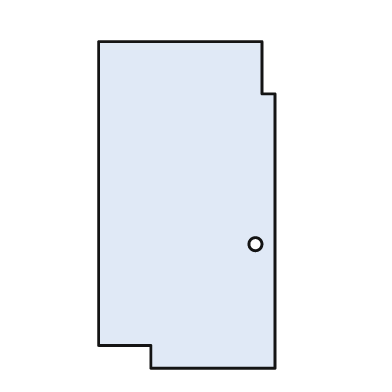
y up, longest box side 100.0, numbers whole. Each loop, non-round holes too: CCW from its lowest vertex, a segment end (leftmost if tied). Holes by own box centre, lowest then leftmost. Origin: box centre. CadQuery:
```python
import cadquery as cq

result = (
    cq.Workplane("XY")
    .moveTo(-11.0, -50.0)
    .lineTo(27.0, -50.0)
    .lineTo(27.0, 34.0)
    .lineTo(23.0, 34.0)
    .lineTo(23.0, 50.0)
    .lineTo(-27.0, 50.0)
    .lineTo(-27.0, -43.0)
    .lineTo(-11.0, -43.0)
    .close()
    .moveTo(21.0, -12.0)
    .circle(2.0)
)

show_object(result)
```